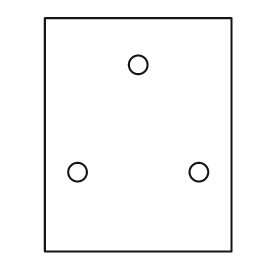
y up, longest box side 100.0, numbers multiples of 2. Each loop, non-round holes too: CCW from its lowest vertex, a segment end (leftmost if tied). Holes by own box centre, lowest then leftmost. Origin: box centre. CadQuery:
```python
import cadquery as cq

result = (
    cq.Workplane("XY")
    .moveTo(-40.0, -50.0)
    .lineTo(40.0, -50.0)
    .lineTo(40.0, 50.0)
    .lineTo(-40.0, 50.0)
    .close()
    .moveTo(-26.0, -16.0)
    .circle(4.0)
    .moveTo(26.0, -16.0)
    .circle(4.0)
    .moveTo(0.0, 30.0)
    .circle(4.0)
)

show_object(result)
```